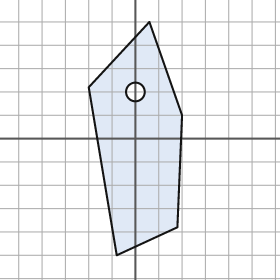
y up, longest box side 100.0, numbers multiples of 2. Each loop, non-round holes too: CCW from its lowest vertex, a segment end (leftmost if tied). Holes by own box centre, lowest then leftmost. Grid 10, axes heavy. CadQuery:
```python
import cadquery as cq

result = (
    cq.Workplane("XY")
    .moveTo(-8.0, -50.0)
    .lineTo(18.0, -38.0)
    .lineTo(20.0, 10.0)
    .lineTo(6.0, 50.0)
    .lineTo(-20.0, 22.0)
    .close()
    .moveTo(0.0, 20.0)
    .circle(4.0)
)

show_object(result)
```